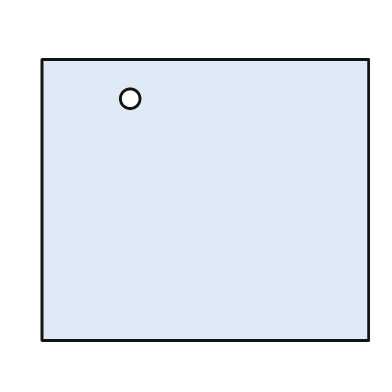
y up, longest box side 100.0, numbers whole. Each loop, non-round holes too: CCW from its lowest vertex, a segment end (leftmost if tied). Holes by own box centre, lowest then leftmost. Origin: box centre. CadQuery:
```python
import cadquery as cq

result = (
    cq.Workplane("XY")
    .moveTo(-50.0, -43.0)
    .lineTo(50.0, -43.0)
    .lineTo(50.0, 43.0)
    .lineTo(-50.0, 43.0)
    .close()
    .moveTo(-23.0, 31.0)
    .circle(3.0)
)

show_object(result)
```